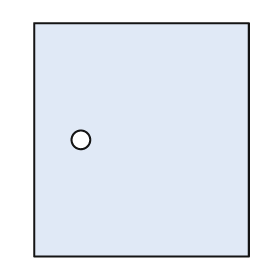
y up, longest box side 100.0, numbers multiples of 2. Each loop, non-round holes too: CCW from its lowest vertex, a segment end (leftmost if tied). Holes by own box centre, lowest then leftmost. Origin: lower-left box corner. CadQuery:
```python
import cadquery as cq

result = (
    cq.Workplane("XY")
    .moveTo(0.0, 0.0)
    .lineTo(92.0, 0.0)
    .lineTo(92.0, 100.0)
    .lineTo(0.0, 100.0)
    .close()
    .moveTo(20.0, 50.0)
    .circle(4.0)
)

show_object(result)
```